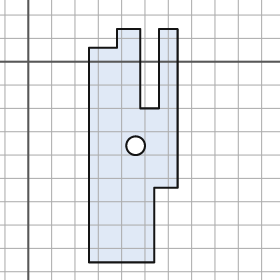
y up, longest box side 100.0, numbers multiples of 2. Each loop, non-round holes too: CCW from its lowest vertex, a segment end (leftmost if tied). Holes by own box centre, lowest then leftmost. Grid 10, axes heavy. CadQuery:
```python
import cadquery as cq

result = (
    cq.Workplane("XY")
    .moveTo(26.0, -86.0)
    .lineTo(54.0, -86.0)
    .lineTo(54.0, -54.0)
    .lineTo(64.0, -54.0)
    .lineTo(64.0, 14.0)
    .lineTo(56.0, 14.0)
    .lineTo(56.0, -20.0)
    .lineTo(48.0, -20.0)
    .lineTo(48.0, 14.0)
    .lineTo(38.0, 14.0)
    .lineTo(38.0, 6.0)
    .lineTo(26.0, 6.0)
    .close()
    .moveTo(46.0, -36.0)
    .circle(4.0)
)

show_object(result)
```